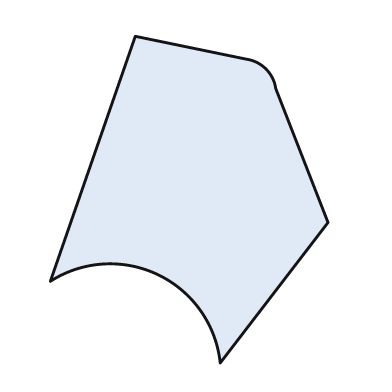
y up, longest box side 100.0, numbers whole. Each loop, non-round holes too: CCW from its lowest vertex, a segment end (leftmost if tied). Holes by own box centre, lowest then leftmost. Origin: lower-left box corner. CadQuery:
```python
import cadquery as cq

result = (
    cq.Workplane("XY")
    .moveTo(52.0, 0.0)
    .lineTo(85.0, 43.0)
    .lineTo(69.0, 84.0)
    .threePointArc((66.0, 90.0), (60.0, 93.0))
    .lineTo(26.0, 100.0)
    .lineTo(0.0, 25.0)
    .threePointArc((33.0, 27.0), (52.0, 0.0))
    .close()
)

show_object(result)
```